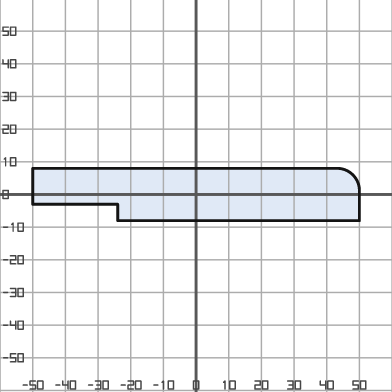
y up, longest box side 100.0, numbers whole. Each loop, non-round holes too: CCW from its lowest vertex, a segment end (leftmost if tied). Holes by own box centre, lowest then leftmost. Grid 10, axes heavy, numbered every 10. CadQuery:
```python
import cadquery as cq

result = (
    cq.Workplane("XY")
    .moveTo(-24.0, -8.0)
    .lineTo(50.0, -8.0)
    .lineTo(50.0, 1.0)
    .threePointArc((48.0, 6.0), (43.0, 8.0))
    .lineTo(-50.0, 8.0)
    .lineTo(-50.0, -3.0)
    .lineTo(-24.0, -3.0)
    .close()
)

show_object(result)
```